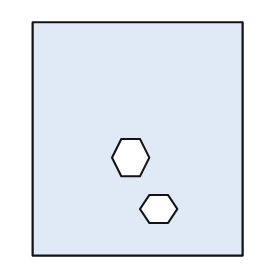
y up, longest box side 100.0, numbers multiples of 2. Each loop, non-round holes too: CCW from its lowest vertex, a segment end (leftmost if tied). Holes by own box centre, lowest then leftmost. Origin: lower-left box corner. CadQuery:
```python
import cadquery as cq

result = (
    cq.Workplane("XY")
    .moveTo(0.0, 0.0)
    .lineTo(90.0, 0.0)
    .lineTo(90.0, 100.0)
    .lineTo(0.0, 100.0)
    .close()
    .moveTo(50.0, 14.0)
    .lineTo(58.0, 14.0)
    .lineTo(62.0, 20.0)
    .lineTo(58.0, 26.0)
    .lineTo(50.0, 26.0)
    .lineTo(46.0, 20.0)
    .close()
    .moveTo(38.0, 34.0)
    .lineTo(46.0, 34.0)
    .lineTo(50.0, 42.0)
    .lineTo(46.0, 50.0)
    .lineTo(38.0, 50.0)
    .lineTo(34.0, 42.0)
    .close()
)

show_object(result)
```